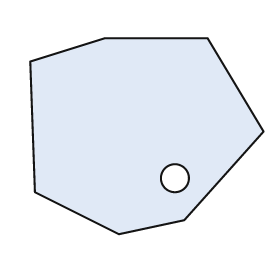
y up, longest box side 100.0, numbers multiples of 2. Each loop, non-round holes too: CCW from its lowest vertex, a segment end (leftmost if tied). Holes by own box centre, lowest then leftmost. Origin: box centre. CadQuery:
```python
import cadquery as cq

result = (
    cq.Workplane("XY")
    .moveTo(-12.0, -42.0)
    .lineTo(16.0, -36.0)
    .lineTo(50.0, 2.0)
    .lineTo(26.0, 42.0)
    .lineTo(-18.0, 42.0)
    .lineTo(-50.0, 32.0)
    .lineTo(-48.0, -24.0)
    .close()
    .moveTo(12.0, -18.0)
    .circle(6.0)
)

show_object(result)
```